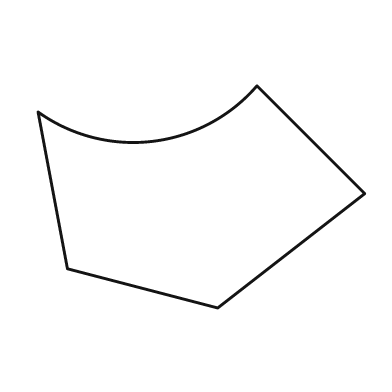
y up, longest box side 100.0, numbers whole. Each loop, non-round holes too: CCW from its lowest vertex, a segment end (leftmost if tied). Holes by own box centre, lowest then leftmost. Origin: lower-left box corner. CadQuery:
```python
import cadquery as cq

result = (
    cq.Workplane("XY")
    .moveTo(55.0, 0.0)
    .lineTo(100.0, 35.0)
    .lineTo(67.0, 68.0)
    .threePointArc((35.0, 51.0), (0.0, 60.0))
    .lineTo(9.0, 12.0)
    .close()
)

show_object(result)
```